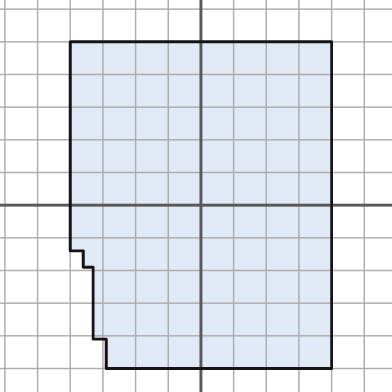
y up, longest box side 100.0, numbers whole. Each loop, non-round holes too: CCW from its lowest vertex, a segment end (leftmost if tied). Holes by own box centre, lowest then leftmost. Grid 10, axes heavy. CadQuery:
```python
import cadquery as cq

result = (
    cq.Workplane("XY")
    .moveTo(-29.0, -50.0)
    .lineTo(40.0, -50.0)
    .lineTo(40.0, 50.0)
    .lineTo(-40.0, 50.0)
    .lineTo(-40.0, -14.0)
    .lineTo(-36.0, -14.0)
    .lineTo(-36.0, -19.0)
    .lineTo(-33.0, -19.0)
    .lineTo(-33.0, -41.0)
    .lineTo(-29.0, -41.0)
    .close()
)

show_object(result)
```